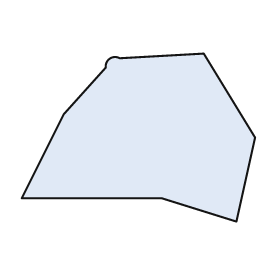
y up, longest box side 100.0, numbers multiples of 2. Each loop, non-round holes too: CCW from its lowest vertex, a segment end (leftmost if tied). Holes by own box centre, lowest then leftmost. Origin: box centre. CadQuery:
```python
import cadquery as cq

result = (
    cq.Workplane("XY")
    .moveTo(42.0, -36.0)
    .lineTo(50.0, 0.0)
    .lineTo(28.0, 36.0)
    .lineTo(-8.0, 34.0)
    .threePointArc((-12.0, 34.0), (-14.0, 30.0))
    .lineTo(-32.0, 10.0)
    .lineTo(-50.0, -26.0)
    .lineTo(10.0, -26.0)
    .close()
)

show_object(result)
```